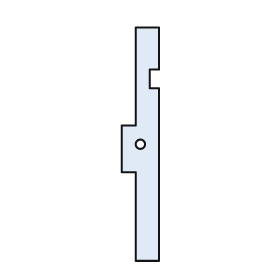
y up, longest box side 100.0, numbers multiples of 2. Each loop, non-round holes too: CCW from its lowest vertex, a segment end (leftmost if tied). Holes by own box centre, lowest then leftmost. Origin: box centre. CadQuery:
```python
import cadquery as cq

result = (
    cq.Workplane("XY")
    .moveTo(-2.0, -50.0)
    .lineTo(8.0, -50.0)
    .lineTo(8.0, 24.0)
    .lineTo(4.0, 24.0)
    .lineTo(4.0, 32.0)
    .lineTo(8.0, 32.0)
    .lineTo(8.0, 50.0)
    .lineTo(-2.0, 50.0)
    .lineTo(-2.0, 8.0)
    .lineTo(-8.0, 8.0)
    .lineTo(-8.0, -12.0)
    .lineTo(-2.0, -12.0)
    .close()
    .moveTo(0.0, 0.0)
    .circle(2.0)
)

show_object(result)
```